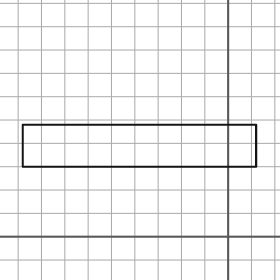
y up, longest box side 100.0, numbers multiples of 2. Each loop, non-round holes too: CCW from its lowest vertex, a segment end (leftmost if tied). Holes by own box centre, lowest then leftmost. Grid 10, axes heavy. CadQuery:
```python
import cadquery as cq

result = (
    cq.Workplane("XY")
    .moveTo(-88.0, 30.0)
    .lineTo(12.0, 30.0)
    .lineTo(12.0, 48.0)
    .lineTo(-88.0, 48.0)
    .close()
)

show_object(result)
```